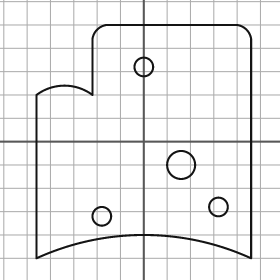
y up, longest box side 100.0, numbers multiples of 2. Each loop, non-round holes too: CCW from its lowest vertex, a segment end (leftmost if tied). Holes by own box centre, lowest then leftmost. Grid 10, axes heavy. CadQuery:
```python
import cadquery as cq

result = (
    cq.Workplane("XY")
    .moveTo(-46.0, -50.0)
    .threePointArc((0.0, -40.0), (46.0, -50.0))
    .lineTo(46.0, 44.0)
    .threePointArc((44.0, 48.0), (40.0, 50.0))
    .lineTo(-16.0, 50.0)
    .threePointArc((-20.0, 48.0), (-22.0, 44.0))
    .lineTo(-22.0, 20.0)
    .threePointArc((-34.0, 24.0), (-46.0, 20.0))
    .close()
    .moveTo(-18.0, -32.0)
    .circle(4.0)
    .moveTo(32.0, -28.0)
    .circle(4.0)
    .moveTo(16.0, -10.0)
    .circle(6.0)
    .moveTo(0.0, 32.0)
    .circle(4.0)
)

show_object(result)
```